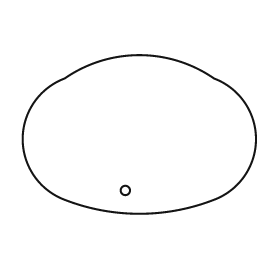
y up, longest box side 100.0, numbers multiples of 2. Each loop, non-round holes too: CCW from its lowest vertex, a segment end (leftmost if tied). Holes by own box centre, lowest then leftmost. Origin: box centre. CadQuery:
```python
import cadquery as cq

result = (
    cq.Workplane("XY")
    .moveTo(-32.0, -28.0)
    .threePointArc((0.0, -34.0), (32.0, -28.0))
    .threePointArc((50.0, -2.0), (32.0, 24.0))
    .threePointArc((0.0, 34.0), (-32.0, 24.0))
    .threePointArc((-50.0, -2.0), (-32.0, -28.0))
    .close()
    .moveTo(-6.0, -24.0)
    .circle(2.0)
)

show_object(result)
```